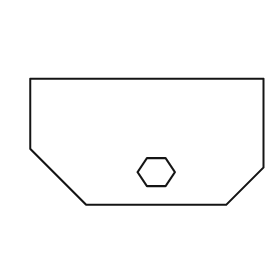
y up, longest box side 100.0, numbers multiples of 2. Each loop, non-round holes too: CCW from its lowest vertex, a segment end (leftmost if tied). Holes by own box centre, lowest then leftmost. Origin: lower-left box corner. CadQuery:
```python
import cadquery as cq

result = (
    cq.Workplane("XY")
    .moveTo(24.0, 0.0)
    .lineTo(84.0, 0.0)
    .lineTo(100.0, 16.0)
    .lineTo(100.0, 54.0)
    .lineTo(0.0, 54.0)
    .lineTo(0.0, 24.0)
    .close()
    .moveTo(50.0, 8.0)
    .lineTo(58.0, 8.0)
    .lineTo(62.0, 14.0)
    .lineTo(58.0, 20.0)
    .lineTo(50.0, 20.0)
    .lineTo(46.0, 14.0)
    .close()
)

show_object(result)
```